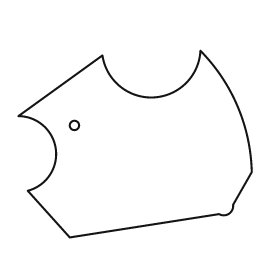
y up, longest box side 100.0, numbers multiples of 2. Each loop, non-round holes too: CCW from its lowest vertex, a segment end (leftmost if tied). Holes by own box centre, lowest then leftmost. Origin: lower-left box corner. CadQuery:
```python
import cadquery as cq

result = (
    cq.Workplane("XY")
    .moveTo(22.0, 0.0)
    .lineTo(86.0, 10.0)
    .threePointArc((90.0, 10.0), (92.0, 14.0))
    .lineTo(100.0, 28.0)
    .threePointArc((94.0, 56.0), (78.0, 80.0))
    .threePointArc((58.0, 60.0), (36.0, 78.0))
    .lineTo(0.0, 52.0)
    .threePointArc((16.0, 38.0), (4.0, 20.0))
    .close()
    .moveTo(24.0, 48.0)
    .circle(2.0)
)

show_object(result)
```